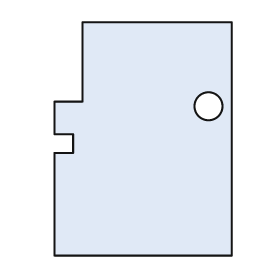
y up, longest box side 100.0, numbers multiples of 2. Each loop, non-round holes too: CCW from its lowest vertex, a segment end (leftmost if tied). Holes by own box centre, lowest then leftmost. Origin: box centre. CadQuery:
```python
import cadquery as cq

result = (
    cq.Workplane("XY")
    .moveTo(-38.0, -50.0)
    .lineTo(38.0, -50.0)
    .lineTo(38.0, 50.0)
    .lineTo(-26.0, 50.0)
    .lineTo(-26.0, 16.0)
    .lineTo(-38.0, 16.0)
    .lineTo(-38.0, 2.0)
    .lineTo(-30.0, 2.0)
    .lineTo(-30.0, -6.0)
    .lineTo(-38.0, -6.0)
    .close()
    .moveTo(28.0, 14.0)
    .circle(6.0)
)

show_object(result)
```